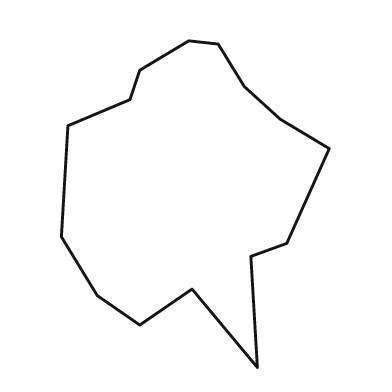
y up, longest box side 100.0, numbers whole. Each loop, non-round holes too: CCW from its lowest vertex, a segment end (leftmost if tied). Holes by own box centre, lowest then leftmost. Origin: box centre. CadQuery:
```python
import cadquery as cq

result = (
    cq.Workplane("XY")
    .moveTo(19.0, -50.0)
    .lineTo(17.0, -16.0)
    .lineTo(28.0, -12.0)
    .lineTo(41.0, 17.0)
    .lineTo(26.0, 26.0)
    .lineTo(15.0, 36.0)
    .lineTo(7.0, 49.0)
    .lineTo(-2.0, 50.0)
    .lineTo(-17.0, 41.0)
    .lineTo(-20.0, 32.0)
    .lineTo(-39.0, 24.0)
    .lineTo(-41.0, -10.0)
    .lineTo(-30.0, -28.0)
    .lineTo(-17.0, -37.0)
    .lineTo(-1.0, -26.0)
    .close()
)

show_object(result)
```